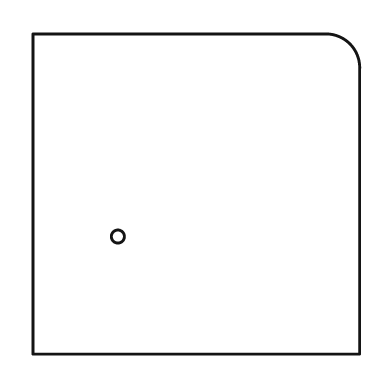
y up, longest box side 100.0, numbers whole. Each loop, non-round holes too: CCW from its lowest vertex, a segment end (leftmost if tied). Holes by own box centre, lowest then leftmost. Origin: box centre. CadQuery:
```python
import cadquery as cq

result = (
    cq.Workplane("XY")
    .moveTo(-50.0, -49.0)
    .lineTo(50.0, -49.0)
    .lineTo(50.0, 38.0)
    .threePointArc((47.0, 46.0), (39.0, 49.0))
    .lineTo(-50.0, 49.0)
    .close()
    .moveTo(-24.0, -13.0)
    .circle(2.0)
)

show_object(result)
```